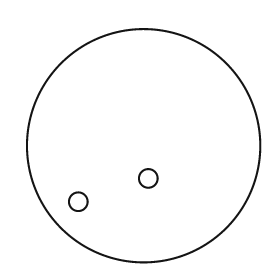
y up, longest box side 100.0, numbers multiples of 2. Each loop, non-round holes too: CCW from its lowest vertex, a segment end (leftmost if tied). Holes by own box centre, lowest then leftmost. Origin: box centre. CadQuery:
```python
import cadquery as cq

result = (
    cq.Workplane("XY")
    .moveTo(0.0, 0.0)
    .circle(50.0)
    .moveTo(-28.0, -24.0)
    .circle(4.0)
    .moveTo(2.0, -14.0)
    .circle(4.0)
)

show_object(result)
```